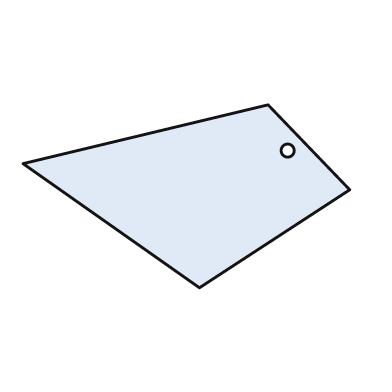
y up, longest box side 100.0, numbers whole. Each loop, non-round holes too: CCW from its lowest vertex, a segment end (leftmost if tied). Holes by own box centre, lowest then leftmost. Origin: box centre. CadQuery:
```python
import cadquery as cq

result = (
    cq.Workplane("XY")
    .moveTo(4.0, -28.0)
    .lineTo(50.0, 2.0)
    .lineTo(25.0, 28.0)
    .lineTo(-50.0, 10.0)
    .close()
    .moveTo(31.0, 14.0)
    .circle(2.0)
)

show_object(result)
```